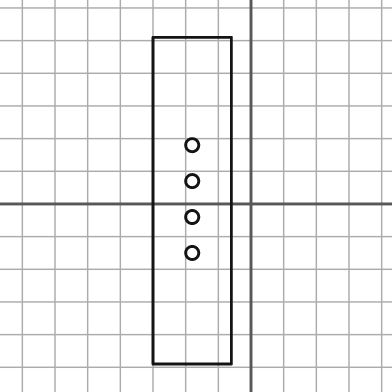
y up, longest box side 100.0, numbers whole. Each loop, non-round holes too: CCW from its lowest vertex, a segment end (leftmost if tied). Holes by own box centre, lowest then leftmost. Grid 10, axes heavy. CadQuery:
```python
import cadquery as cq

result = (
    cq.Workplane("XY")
    .moveTo(-30.0, -49.0)
    .lineTo(-6.0, -49.0)
    .lineTo(-6.0, 51.0)
    .lineTo(-30.0, 51.0)
    .close()
    .moveTo(-18.0, -15.0)
    .circle(2.0)
    .moveTo(-18.0, -4.0)
    .circle(2.0)
    .moveTo(-18.0, 7.0)
    .circle(2.0)
    .moveTo(-18.0, 18.0)
    .circle(2.0)
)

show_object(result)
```